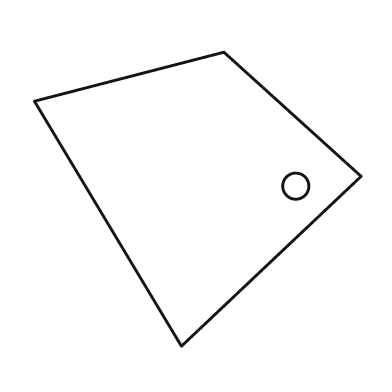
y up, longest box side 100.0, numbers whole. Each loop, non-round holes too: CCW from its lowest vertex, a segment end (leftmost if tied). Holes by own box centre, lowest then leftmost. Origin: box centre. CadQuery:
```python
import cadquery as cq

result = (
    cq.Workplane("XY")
    .moveTo(-5.0, -45.0)
    .lineTo(50.0, 7.0)
    .lineTo(8.0, 45.0)
    .lineTo(-50.0, 30.0)
    .close()
    .moveTo(30.0, 4.0)
    .circle(4.0)
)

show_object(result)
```